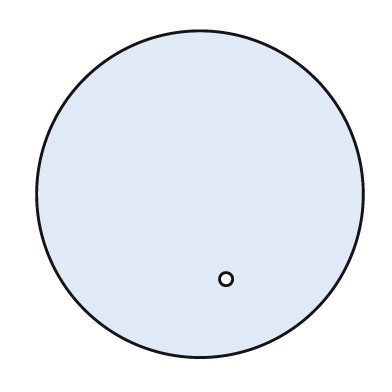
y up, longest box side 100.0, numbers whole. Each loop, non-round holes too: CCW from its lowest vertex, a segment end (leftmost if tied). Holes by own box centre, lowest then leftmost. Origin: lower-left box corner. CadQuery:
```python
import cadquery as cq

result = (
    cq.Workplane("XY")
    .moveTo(50.0, 50.0)
    .circle(50.0)
    .moveTo(58.0, 24.0)
    .circle(2.0)
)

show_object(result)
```